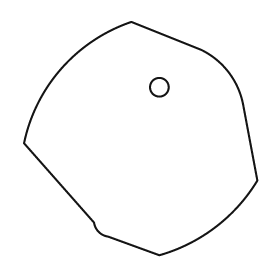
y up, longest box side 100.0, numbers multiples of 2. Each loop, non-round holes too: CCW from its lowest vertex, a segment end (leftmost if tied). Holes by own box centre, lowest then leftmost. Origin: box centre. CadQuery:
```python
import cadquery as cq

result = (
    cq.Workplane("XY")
    .moveTo(8.0, -50.0)
    .threePointArc((32.0, -38.0), (50.0, -18.0))
    .lineTo(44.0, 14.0)
    .threePointArc((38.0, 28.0), (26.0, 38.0))
    .lineTo(-4.0, 50.0)
    .threePointArc((-34.0, 30.0), (-50.0, -2.0))
    .lineTo(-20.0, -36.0)
    .threePointArc((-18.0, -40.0), (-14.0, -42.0))
    .close()
    .moveTo(8.0, 22.0)
    .circle(4.0)
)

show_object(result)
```